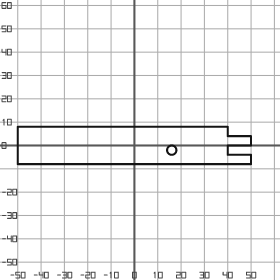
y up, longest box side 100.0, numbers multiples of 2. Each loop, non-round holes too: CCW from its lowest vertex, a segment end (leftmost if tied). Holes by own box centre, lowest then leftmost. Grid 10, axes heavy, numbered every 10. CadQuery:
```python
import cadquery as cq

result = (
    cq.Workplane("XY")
    .moveTo(-50.0, -8.0)
    .lineTo(50.0, -8.0)
    .lineTo(50.0, -4.0)
    .lineTo(40.0, -4.0)
    .lineTo(40.0, 0.0)
    .lineTo(50.0, 0.0)
    .lineTo(50.0, 4.0)
    .lineTo(40.0, 4.0)
    .lineTo(40.0, 8.0)
    .lineTo(-50.0, 8.0)
    .close()
    .moveTo(16.0, -2.0)
    .circle(2.0)
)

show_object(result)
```